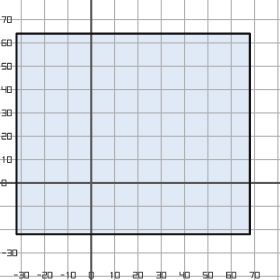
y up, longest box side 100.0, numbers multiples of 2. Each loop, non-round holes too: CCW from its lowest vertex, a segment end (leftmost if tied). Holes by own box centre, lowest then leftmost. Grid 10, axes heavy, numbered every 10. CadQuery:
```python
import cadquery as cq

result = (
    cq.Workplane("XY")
    .moveTo(-32.0, -22.0)
    .lineTo(68.0, -22.0)
    .lineTo(68.0, 64.0)
    .lineTo(-32.0, 64.0)
    .close()
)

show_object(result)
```